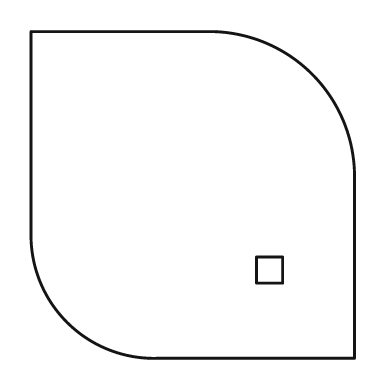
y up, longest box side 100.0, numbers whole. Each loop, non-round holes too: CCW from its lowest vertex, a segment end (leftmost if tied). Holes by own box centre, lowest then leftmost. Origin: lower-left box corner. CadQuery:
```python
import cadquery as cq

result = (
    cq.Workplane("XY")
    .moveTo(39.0, 0.0)
    .lineTo(99.0, 0.0)
    .lineTo(99.0, 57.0)
    .threePointArc((86.0, 87.0), (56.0, 100.0))
    .lineTo(0.0, 100.0)
    .lineTo(0.0, 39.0)
    .threePointArc((11.0, 11.0), (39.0, 0.0))
    .close()
    .moveTo(69.0, 23.0)
    .lineTo(77.0, 23.0)
    .lineTo(77.0, 31.0)
    .lineTo(69.0, 31.0)
    .close()
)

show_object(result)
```